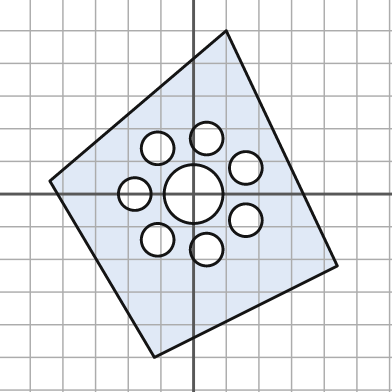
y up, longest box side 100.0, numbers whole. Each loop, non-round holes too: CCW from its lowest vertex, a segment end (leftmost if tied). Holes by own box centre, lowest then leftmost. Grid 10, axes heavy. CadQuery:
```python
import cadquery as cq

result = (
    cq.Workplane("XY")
    .moveTo(-12.0, -50.0)
    .lineTo(44.0, -22.0)
    .lineTo(10.0, 50.0)
    .lineTo(-44.0, 4.0)
    .close()
    .moveTo(4.0, -17.0)
    .circle(5.0)
    .moveTo(-11.0, -14.0)
    .circle(5.0)
    .moveTo(16.0, -8.0)
    .circle(5.0)
    .moveTo(-18.0, 0.0)
    .circle(5.0)
    .moveTo(0.0, 0.0)
    .circle(9.0)
    .moveTo(16.0, 8.0)
    .circle(5.0)
    .moveTo(-11.0, 14.0)
    .circle(5.0)
    .moveTo(4.0, 17.0)
    .circle(5.0)
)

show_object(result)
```